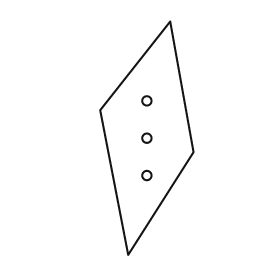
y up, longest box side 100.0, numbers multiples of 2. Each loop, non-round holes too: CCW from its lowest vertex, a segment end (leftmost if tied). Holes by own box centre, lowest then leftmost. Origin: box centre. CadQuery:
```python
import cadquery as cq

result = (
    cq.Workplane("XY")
    .moveTo(-8.0, -50.0)
    .lineTo(20.0, -6.0)
    .lineTo(10.0, 50.0)
    .lineTo(-20.0, 12.0)
    .close()
    .moveTo(0.0, -16.0)
    .circle(2.0)
    .moveTo(0.0, 0.0)
    .circle(2.0)
    .moveTo(0.0, 16.0)
    .circle(2.0)
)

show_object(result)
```